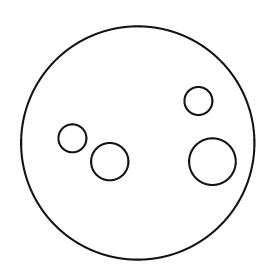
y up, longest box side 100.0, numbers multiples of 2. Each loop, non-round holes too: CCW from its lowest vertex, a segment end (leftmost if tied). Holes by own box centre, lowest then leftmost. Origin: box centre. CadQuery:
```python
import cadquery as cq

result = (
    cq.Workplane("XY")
    .moveTo(0.0, 0.0)
    .circle(50.0)
    .moveTo(-12.0, -8.0)
    .circle(8.0)
    .moveTo(32.0, -8.0)
    .circle(10.0)
    .moveTo(-28.0, 2.0)
    .circle(6.0)
    .moveTo(26.0, 18.0)
    .circle(6.0)
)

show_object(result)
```